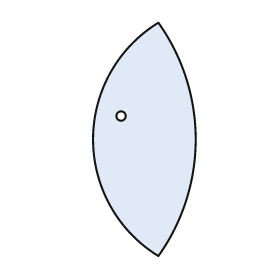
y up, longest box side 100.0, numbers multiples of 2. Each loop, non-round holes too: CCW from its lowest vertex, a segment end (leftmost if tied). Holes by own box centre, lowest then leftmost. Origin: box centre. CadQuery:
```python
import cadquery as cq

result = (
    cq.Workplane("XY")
    .moveTo(6.0, -50.0)
    .threePointArc((22.0, 0.0), (6.0, 50.0))
    .threePointArc((-22.0, 0.0), (6.0, -50.0))
    .close()
    .moveTo(-10.0, 10.0)
    .circle(2.0)
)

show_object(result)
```